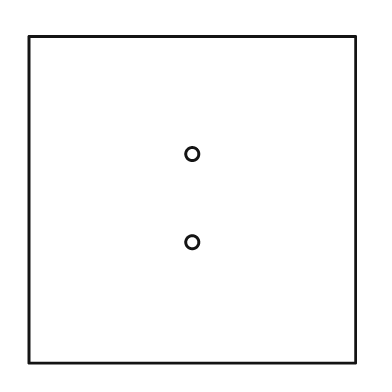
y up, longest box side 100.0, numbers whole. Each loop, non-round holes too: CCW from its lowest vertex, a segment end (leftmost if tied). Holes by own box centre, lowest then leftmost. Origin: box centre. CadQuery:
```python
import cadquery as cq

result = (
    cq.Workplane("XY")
    .moveTo(-50.0, -50.0)
    .lineTo(50.0, -50.0)
    .lineTo(50.0, 50.0)
    .lineTo(-50.0, 50.0)
    .close()
    .moveTo(0.0, -13.0)
    .circle(2.0)
    .moveTo(0.0, 14.0)
    .circle(2.0)
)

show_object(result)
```